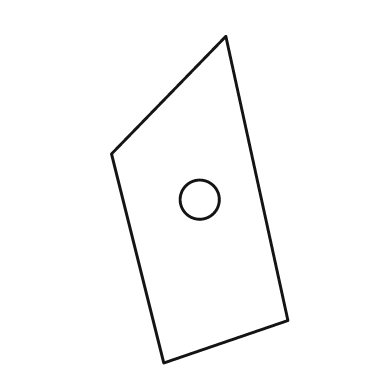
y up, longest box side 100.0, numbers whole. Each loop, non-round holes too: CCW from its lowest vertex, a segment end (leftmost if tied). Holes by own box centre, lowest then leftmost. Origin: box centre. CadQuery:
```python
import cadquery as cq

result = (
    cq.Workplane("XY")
    .moveTo(-11.0, -50.0)
    .lineTo(27.0, -37.0)
    .lineTo(8.0, 50.0)
    .lineTo(-27.0, 14.0)
    .close()
    .moveTo(0.0, 0.0)
    .circle(6.0)
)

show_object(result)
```